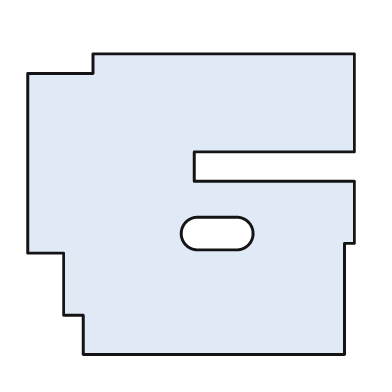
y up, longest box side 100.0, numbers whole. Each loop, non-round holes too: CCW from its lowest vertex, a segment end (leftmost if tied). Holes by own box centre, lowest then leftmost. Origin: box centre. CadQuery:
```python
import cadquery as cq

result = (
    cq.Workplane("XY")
    .moveTo(-33.0, -46.0)
    .lineTo(47.0, -46.0)
    .lineTo(47.0, -12.0)
    .lineTo(50.0, -12.0)
    .lineTo(50.0, 7.0)
    .lineTo(1.0, 7.0)
    .lineTo(1.0, 16.0)
    .lineTo(50.0, 16.0)
    .lineTo(50.0, 46.0)
    .lineTo(-30.0, 46.0)
    .lineTo(-30.0, 40.0)
    .lineTo(-50.0, 40.0)
    .lineTo(-50.0, -15.0)
    .lineTo(-39.0, -15.0)
    .lineTo(-39.0, -34.0)
    .lineTo(-33.0, -34.0)
    .close()
    .moveTo(2.0, -14.0)
    .lineTo(14.0, -14.0)
    .threePointArc((19.0, -9.0), (14.0, -4.0))
    .lineTo(2.0, -4.0)
    .threePointArc((-3.0, -9.0), (2.0, -14.0))
    .close()
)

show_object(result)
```